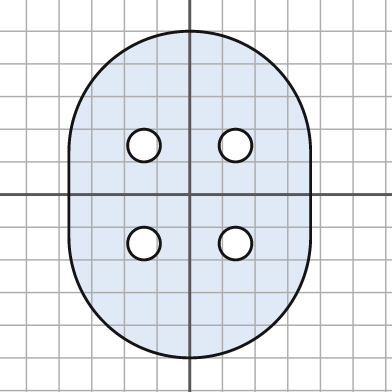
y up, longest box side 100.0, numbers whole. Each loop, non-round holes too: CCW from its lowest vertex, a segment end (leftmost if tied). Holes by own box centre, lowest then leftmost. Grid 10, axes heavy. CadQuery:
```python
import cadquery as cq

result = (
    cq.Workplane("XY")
    .moveTo(-37.0, -13.0)
    .threePointArc((0.0, -50.0), (37.0, -13.0))
    .lineTo(37.0, 13.0)
    .threePointArc((0.0, 50.0), (-37.0, 13.0))
    .close()
    .moveTo(-14.0, -15.0)
    .circle(5.0)
    .moveTo(14.0, -15.0)
    .circle(5.0)
    .moveTo(-14.0, 15.0)
    .circle(5.0)
    .moveTo(14.0, 15.0)
    .circle(5.0)
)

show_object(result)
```